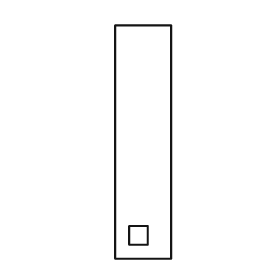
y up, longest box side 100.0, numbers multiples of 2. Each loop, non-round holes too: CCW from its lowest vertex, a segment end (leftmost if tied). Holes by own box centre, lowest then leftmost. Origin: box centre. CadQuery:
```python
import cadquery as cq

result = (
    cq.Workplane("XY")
    .moveTo(-12.0, -50.0)
    .lineTo(12.0, -50.0)
    .lineTo(12.0, 50.0)
    .lineTo(-12.0, 50.0)
    .close()
    .moveTo(-6.0, -44.0)
    .lineTo(2.0, -44.0)
    .lineTo(2.0, -36.0)
    .lineTo(-6.0, -36.0)
    .close()
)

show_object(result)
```